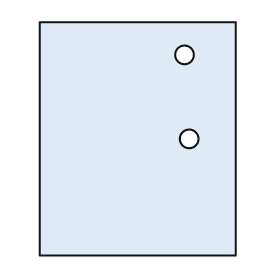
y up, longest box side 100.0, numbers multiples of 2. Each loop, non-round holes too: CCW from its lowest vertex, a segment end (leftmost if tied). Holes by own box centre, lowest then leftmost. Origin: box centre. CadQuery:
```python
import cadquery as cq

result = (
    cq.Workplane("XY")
    .moveTo(-42.0, -50.0)
    .lineTo(42.0, -50.0)
    .lineTo(42.0, 50.0)
    .lineTo(-42.0, 50.0)
    .close()
    .moveTo(22.0, 0.0)
    .circle(4.0)
    .moveTo(20.0, 36.0)
    .circle(4.0)
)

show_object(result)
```